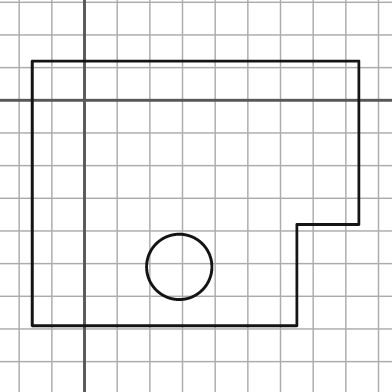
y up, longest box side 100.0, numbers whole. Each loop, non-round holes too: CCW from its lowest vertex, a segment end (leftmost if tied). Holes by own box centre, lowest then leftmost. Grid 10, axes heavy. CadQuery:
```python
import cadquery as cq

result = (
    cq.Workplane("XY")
    .moveTo(-16.0, -69.0)
    .lineTo(65.0, -69.0)
    .lineTo(65.0, -38.0)
    .lineTo(84.0, -38.0)
    .lineTo(84.0, 12.0)
    .lineTo(-16.0, 12.0)
    .close()
    .moveTo(29.0, -51.0)
    .circle(10.0)
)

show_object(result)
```